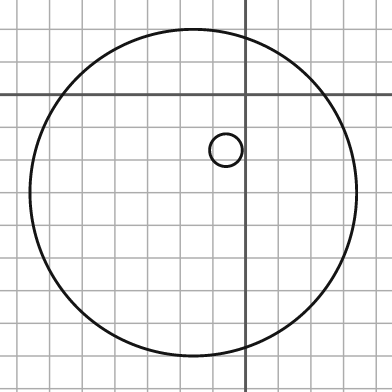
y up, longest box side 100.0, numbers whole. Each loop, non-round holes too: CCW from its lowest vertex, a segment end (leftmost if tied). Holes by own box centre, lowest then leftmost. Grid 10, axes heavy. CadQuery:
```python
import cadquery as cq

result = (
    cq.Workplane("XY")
    .moveTo(-16.0, -30.0)
    .circle(50.0)
    .moveTo(-6.0, -17.0)
    .circle(5.0)
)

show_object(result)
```